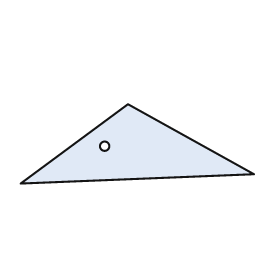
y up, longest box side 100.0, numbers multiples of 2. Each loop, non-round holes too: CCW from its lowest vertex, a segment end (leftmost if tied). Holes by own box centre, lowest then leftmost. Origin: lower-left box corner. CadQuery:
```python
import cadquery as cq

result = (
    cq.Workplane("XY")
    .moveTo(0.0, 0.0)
    .lineTo(100.0, 4.0)
    .lineTo(46.0, 34.0)
    .close()
    .moveTo(36.0, 16.0)
    .circle(2.0)
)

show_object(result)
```